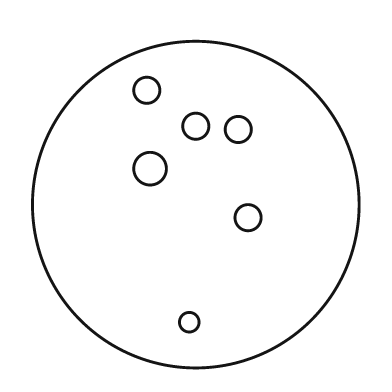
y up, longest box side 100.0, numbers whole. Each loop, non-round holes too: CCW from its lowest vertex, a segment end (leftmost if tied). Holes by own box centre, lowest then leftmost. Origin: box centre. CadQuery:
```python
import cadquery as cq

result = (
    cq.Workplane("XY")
    .moveTo(0.0, 0.0)
    .circle(50.0)
    .moveTo(-2.0, -36.0)
    .circle(3.0)
    .moveTo(16.0, -4.0)
    .circle(4.0)
    .moveTo(-14.0, 11.0)
    .circle(5.0)
    .moveTo(13.0, 23.0)
    .circle(4.0)
    .moveTo(0.0, 24.0)
    .circle(4.0)
    .moveTo(-15.0, 35.0)
    .circle(4.0)
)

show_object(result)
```